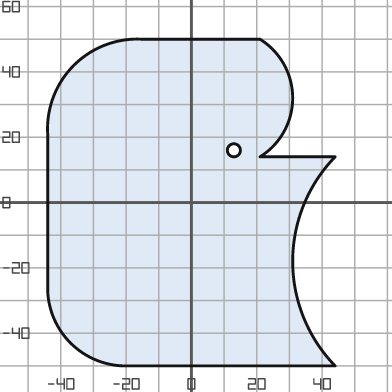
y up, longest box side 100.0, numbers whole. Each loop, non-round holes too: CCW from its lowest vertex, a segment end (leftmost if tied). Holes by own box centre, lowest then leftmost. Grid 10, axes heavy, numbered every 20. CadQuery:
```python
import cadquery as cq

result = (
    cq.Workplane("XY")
    .moveTo(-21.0, -50.0)
    .lineTo(44.0, -50.0)
    .threePointArc((31.0, -18.0), (44.0, 14.0))
    .lineTo(21.0, 14.0)
    .threePointArc((31.0, 32.0), (21.0, 50.0))
    .lineTo(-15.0, 50.0)
    .threePointArc((-36.0, 42.0), (-44.0, 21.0))
    .lineTo(-44.0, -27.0)
    .threePointArc((-37.0, -43.0), (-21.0, -50.0))
    .close()
    .moveTo(13.0, 16.0)
    .circle(2.0)
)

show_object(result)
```